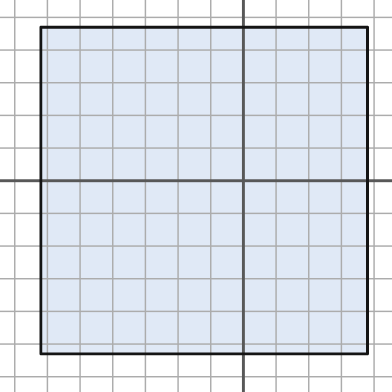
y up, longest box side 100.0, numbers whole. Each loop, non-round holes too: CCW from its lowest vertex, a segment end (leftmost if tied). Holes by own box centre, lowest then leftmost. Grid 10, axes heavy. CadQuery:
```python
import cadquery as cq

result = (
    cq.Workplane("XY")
    .moveTo(-62.0, -53.0)
    .lineTo(38.0, -53.0)
    .lineTo(38.0, 47.0)
    .lineTo(-62.0, 47.0)
    .close()
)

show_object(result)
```